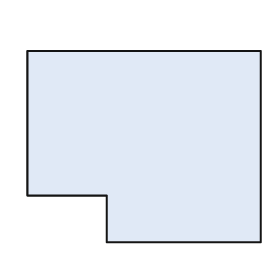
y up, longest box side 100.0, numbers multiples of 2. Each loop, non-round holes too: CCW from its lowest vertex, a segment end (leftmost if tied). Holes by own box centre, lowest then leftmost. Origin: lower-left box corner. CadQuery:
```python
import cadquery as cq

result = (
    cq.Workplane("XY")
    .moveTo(34.0, 0.0)
    .lineTo(100.0, 0.0)
    .lineTo(100.0, 82.0)
    .lineTo(0.0, 82.0)
    .lineTo(0.0, 20.0)
    .lineTo(34.0, 20.0)
    .close()
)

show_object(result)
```